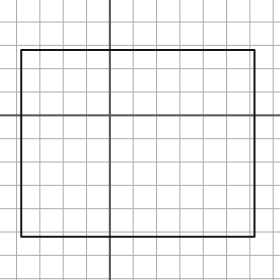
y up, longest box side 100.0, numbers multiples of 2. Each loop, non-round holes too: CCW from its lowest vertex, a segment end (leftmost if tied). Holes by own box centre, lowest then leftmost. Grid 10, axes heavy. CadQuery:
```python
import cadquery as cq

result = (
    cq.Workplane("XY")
    .moveTo(-38.0, -52.0)
    .lineTo(62.0, -52.0)
    .lineTo(62.0, 28.0)
    .lineTo(-38.0, 28.0)
    .close()
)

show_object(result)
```